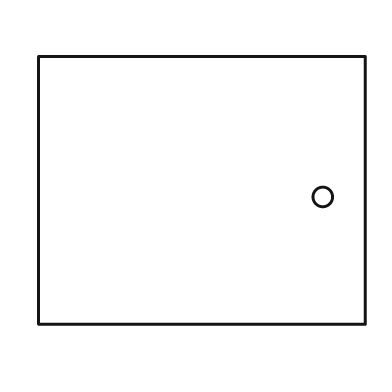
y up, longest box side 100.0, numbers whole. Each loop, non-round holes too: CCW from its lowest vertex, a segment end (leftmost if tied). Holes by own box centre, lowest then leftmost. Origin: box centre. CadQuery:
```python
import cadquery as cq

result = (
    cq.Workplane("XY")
    .moveTo(-50.0, -41.0)
    .lineTo(50.0, -41.0)
    .lineTo(50.0, 41.0)
    .lineTo(-50.0, 41.0)
    .close()
    .moveTo(37.0, -2.0)
    .circle(3.0)
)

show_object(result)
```